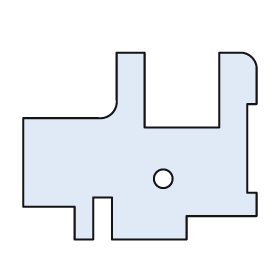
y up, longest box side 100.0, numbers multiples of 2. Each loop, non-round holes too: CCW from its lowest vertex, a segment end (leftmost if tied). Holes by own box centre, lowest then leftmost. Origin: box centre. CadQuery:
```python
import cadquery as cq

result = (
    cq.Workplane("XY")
    .moveTo(-28.0, -40.0)
    .lineTo(-20.0, -40.0)
    .lineTo(-20.0, -22.0)
    .lineTo(-12.0, -22.0)
    .lineTo(-12.0, -40.0)
    .lineTo(20.0, -40.0)
    .lineTo(20.0, -30.0)
    .lineTo(50.0, -30.0)
    .lineTo(50.0, -20.0)
    .lineTo(46.0, -20.0)
    .lineTo(46.0, 18.0)
    .lineTo(50.0, 18.0)
    .lineTo(50.0, 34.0)
    .threePointArc((48.0, 38.0), (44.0, 40.0))
    .lineTo(34.0, 40.0)
    .lineTo(34.0, 8.0)
    .lineTo(2.0, 8.0)
    .lineTo(2.0, 40.0)
    .lineTo(-10.0, 40.0)
    .lineTo(-10.0, 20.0)
    .threePointArc((-12.0, 14.0), (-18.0, 12.0))
    .lineTo(-50.0, 12.0)
    .lineTo(-50.0, -26.0)
    .lineTo(-28.0, -26.0)
    .close()
    .moveTo(10.0, -14.0)
    .circle(4.0)
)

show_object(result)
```